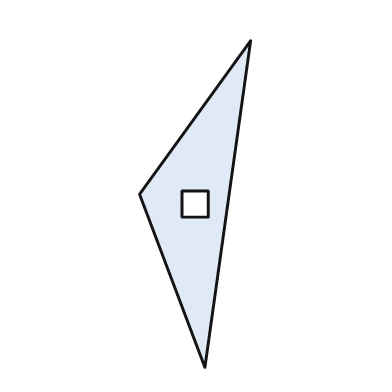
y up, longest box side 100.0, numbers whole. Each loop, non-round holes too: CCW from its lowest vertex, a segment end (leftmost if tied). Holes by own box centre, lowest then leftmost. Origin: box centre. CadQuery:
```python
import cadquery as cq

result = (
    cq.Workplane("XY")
    .moveTo(3.0, -50.0)
    .lineTo(17.0, 50.0)
    .lineTo(-17.0, 3.0)
    .close()
    .moveTo(-4.0, -4.0)
    .lineTo(4.0, -4.0)
    .lineTo(4.0, 4.0)
    .lineTo(-4.0, 4.0)
    .close()
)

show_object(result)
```